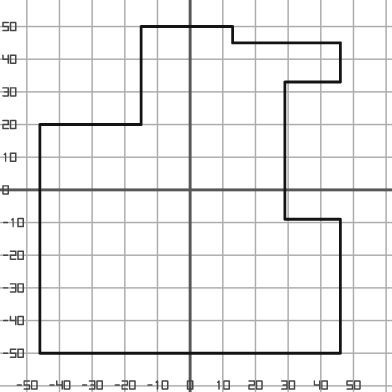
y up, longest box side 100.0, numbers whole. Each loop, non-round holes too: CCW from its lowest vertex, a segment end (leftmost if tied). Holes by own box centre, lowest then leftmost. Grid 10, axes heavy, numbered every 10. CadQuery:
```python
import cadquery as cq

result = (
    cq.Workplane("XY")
    .moveTo(-46.0, -50.0)
    .lineTo(46.0, -50.0)
    .lineTo(46.0, -9.0)
    .lineTo(29.0, -9.0)
    .lineTo(29.0, 33.0)
    .lineTo(46.0, 33.0)
    .lineTo(46.0, 45.0)
    .lineTo(13.0, 45.0)
    .lineTo(13.0, 50.0)
    .lineTo(-15.0, 50.0)
    .lineTo(-15.0, 20.0)
    .lineTo(-46.0, 20.0)
    .close()
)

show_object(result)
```